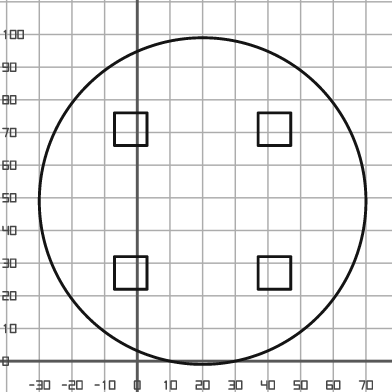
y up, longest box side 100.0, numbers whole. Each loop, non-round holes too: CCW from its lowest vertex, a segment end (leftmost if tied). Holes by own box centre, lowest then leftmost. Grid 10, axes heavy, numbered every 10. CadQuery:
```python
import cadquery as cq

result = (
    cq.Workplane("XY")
    .moveTo(20.0, 49.0)
    .circle(50.0)
    .moveTo(-7.0, 22.0)
    .lineTo(3.0, 22.0)
    .lineTo(3.0, 32.0)
    .lineTo(-7.0, 32.0)
    .close()
    .moveTo(37.0, 22.0)
    .lineTo(47.0, 22.0)
    .lineTo(47.0, 32.0)
    .lineTo(37.0, 32.0)
    .close()
    .moveTo(-7.0, 66.0)
    .lineTo(3.0, 66.0)
    .lineTo(3.0, 76.0)
    .lineTo(-7.0, 76.0)
    .close()
    .moveTo(37.0, 66.0)
    .lineTo(47.0, 66.0)
    .lineTo(47.0, 76.0)
    .lineTo(37.0, 76.0)
    .close()
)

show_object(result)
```